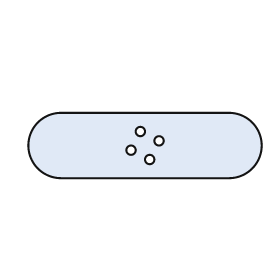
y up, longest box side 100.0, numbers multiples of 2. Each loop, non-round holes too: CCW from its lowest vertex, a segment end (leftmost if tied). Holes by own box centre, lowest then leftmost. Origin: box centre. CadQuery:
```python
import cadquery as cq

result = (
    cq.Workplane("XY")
    .moveTo(-36.0, -14.0)
    .lineTo(36.0, -14.0)
    .threePointArc((50.0, 0.0), (36.0, 14.0))
    .lineTo(-36.0, 14.0)
    .threePointArc((-50.0, 0.0), (-36.0, -14.0))
    .close()
    .moveTo(2.0, -6.0)
    .circle(2.0)
    .moveTo(-6.0, -2.0)
    .circle(2.0)
    .moveTo(6.0, 2.0)
    .circle(2.0)
    .moveTo(-2.0, 6.0)
    .circle(2.0)
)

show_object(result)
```